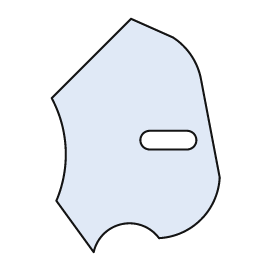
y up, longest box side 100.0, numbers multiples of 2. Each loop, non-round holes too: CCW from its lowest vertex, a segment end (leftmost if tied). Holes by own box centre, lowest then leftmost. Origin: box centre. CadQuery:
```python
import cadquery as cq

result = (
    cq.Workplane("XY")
    .moveTo(-18.0, -50.0)
    .threePointArc((-6.0, -38.0), (10.0, -44.0))
    .threePointArc((28.0, -36.0), (36.0, -18.0))
    .lineTo(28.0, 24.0)
    .threePointArc((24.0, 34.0), (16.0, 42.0))
    .lineTo(-2.0, 50.0)
    .lineTo(-36.0, 16.0)
    .threePointArc((-30.0, -6.0), (-34.0, -28.0))
    .close()
    .moveTo(6.0, -6.0)
    .lineTo(22.0, -6.0)
    .threePointArc((26.0, -2.0), (22.0, 2.0))
    .lineTo(6.0, 2.0)
    .threePointArc((2.0, -2.0), (6.0, -6.0))
    .close()
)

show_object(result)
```